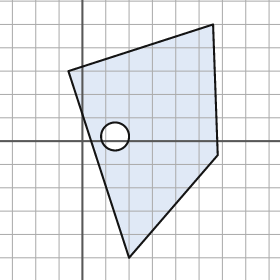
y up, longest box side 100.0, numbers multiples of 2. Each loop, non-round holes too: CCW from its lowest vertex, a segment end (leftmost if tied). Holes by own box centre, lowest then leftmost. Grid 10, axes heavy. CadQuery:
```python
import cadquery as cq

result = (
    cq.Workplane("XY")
    .moveTo(20.0, -50.0)
    .lineTo(58.0, -6.0)
    .lineTo(56.0, 50.0)
    .lineTo(-6.0, 30.0)
    .close()
    .moveTo(14.0, 2.0)
    .circle(6.0)
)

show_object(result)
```